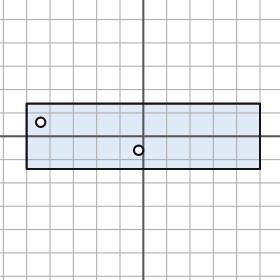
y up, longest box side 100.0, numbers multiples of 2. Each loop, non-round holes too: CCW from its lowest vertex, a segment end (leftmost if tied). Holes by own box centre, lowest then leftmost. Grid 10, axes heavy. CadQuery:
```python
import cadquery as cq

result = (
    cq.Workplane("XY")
    .moveTo(-50.0, -14.0)
    .lineTo(50.0, -14.0)
    .lineTo(50.0, 14.0)
    .lineTo(-50.0, 14.0)
    .close()
    .moveTo(-2.0, -6.0)
    .circle(2.0)
    .moveTo(-44.0, 6.0)
    .circle(2.0)
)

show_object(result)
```